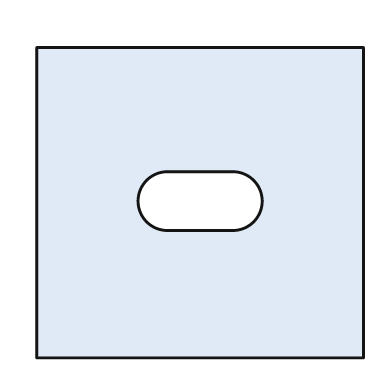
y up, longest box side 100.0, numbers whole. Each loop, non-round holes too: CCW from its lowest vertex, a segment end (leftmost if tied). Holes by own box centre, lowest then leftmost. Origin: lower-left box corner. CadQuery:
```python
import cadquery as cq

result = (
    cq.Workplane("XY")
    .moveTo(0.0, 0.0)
    .lineTo(100.0, 0.0)
    .lineTo(100.0, 95.0)
    .lineTo(0.0, 95.0)
    .close()
    .moveTo(40.0, 39.0)
    .lineTo(60.0, 39.0)
    .threePointArc((69.0, 48.0), (60.0, 57.0))
    .lineTo(40.0, 57.0)
    .threePointArc((31.0, 48.0), (40.0, 39.0))
    .close()
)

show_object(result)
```